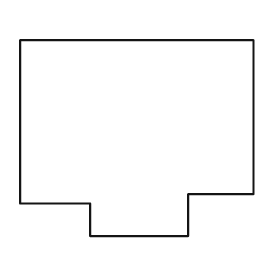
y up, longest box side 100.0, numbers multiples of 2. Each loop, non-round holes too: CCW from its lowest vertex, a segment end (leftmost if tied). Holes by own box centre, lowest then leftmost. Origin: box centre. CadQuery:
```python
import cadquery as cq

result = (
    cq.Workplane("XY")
    .moveTo(-20.0, -42.0)
    .lineTo(22.0, -42.0)
    .lineTo(22.0, -24.0)
    .lineTo(50.0, -24.0)
    .lineTo(50.0, 42.0)
    .lineTo(-50.0, 42.0)
    .lineTo(-50.0, -28.0)
    .lineTo(-20.0, -28.0)
    .close()
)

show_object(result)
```